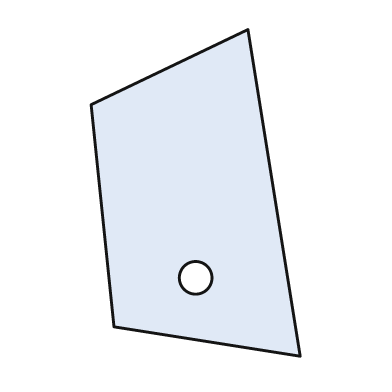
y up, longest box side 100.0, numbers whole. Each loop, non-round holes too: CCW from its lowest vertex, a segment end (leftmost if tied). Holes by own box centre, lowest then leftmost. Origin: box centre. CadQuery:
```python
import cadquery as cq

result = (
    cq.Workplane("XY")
    .moveTo(32.0, -50.0)
    .lineTo(16.0, 50.0)
    .lineTo(-32.0, 27.0)
    .lineTo(-25.0, -41.0)
    .close()
    .moveTo(0.0, -26.0)
    .circle(5.0)
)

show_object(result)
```